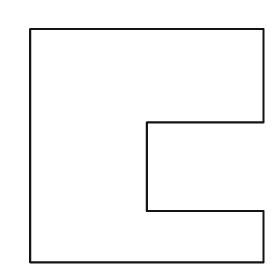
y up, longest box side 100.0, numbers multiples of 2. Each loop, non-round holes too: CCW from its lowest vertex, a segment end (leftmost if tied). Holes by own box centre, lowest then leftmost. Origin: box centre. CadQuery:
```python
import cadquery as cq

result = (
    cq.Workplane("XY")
    .moveTo(-50.0, -50.0)
    .lineTo(50.0, -50.0)
    .lineTo(50.0, -28.0)
    .lineTo(0.0, -28.0)
    .lineTo(0.0, 10.0)
    .lineTo(50.0, 10.0)
    .lineTo(50.0, 50.0)
    .lineTo(-50.0, 50.0)
    .close()
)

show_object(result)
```